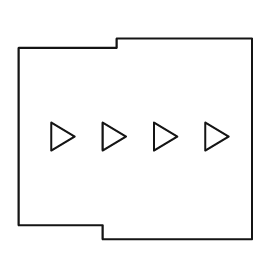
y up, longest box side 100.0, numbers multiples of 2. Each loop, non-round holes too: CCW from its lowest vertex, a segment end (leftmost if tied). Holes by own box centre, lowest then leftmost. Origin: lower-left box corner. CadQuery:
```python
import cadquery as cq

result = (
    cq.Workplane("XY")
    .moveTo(36.0, 0.0)
    .lineTo(100.0, 0.0)
    .lineTo(100.0, 86.0)
    .lineTo(42.0, 86.0)
    .lineTo(42.0, 82.0)
    .lineTo(0.0, 82.0)
    .lineTo(0.0, 6.0)
    .lineTo(36.0, 6.0)
    .close()
    .moveTo(14.0, 38.0)
    .lineTo(24.0, 44.0)
    .lineTo(14.0, 50.0)
    .close()
    .moveTo(36.0, 38.0)
    .lineTo(46.0, 44.0)
    .lineTo(36.0, 50.0)
    .close()
    .moveTo(58.0, 38.0)
    .lineTo(68.0, 44.0)
    .lineTo(58.0, 50.0)
    .close()
    .moveTo(80.0, 38.0)
    .lineTo(90.0, 44.0)
    .lineTo(80.0, 50.0)
    .close()
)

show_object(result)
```